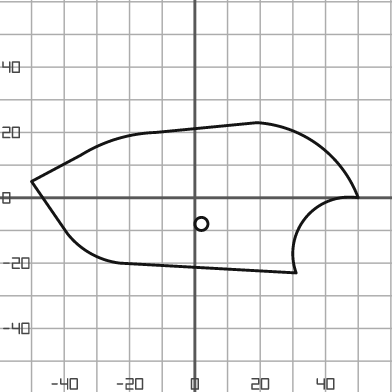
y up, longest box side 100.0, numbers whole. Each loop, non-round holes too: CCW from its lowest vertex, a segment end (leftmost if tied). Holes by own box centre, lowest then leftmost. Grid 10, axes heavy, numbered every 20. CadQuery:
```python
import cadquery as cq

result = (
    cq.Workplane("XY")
    .moveTo(31.0, -23.0)
    .threePointArc((34.0, -6.0), (50.0, 0.0))
    .threePointArc((38.0, 16.0), (19.0, 23.0))
    .lineTo(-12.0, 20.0)
    .threePointArc((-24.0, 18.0), (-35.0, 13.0))
    .lineTo(-50.0, 5.0)
    .lineTo(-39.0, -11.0)
    .threePointArc((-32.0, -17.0), (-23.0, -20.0))
    .close()
    .moveTo(2.0, -8.0)
    .circle(2.0)
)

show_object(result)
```